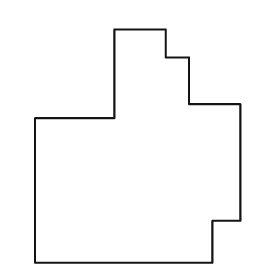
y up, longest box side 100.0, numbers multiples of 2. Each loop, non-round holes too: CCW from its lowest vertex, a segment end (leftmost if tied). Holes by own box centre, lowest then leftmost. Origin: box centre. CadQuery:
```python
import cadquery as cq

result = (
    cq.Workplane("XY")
    .moveTo(-44.0, -50.0)
    .lineTo(32.0, -50.0)
    .lineTo(32.0, -32.0)
    .lineTo(44.0, -32.0)
    .lineTo(44.0, 18.0)
    .lineTo(22.0, 18.0)
    .lineTo(22.0, 38.0)
    .lineTo(12.0, 38.0)
    .lineTo(12.0, 50.0)
    .lineTo(-10.0, 50.0)
    .lineTo(-10.0, 12.0)
    .lineTo(-44.0, 12.0)
    .close()
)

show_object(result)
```